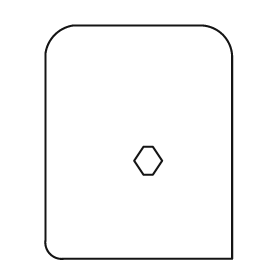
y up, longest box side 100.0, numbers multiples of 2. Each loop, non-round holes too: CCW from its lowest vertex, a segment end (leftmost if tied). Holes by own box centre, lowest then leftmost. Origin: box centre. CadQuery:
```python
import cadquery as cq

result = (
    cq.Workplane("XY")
    .moveTo(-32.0, -50.0)
    .lineTo(40.0, -50.0)
    .lineTo(40.0, 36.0)
    .threePointArc((36.0, 46.0), (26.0, 50.0))
    .lineTo(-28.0, 50.0)
    .threePointArc((-36.0, 46.0), (-40.0, 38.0))
    .lineTo(-40.0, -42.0)
    .threePointArc((-38.0, -48.0), (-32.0, -50.0))
    .close()
    .moveTo(2.0, -14.0)
    .lineTo(6.0, -14.0)
    .lineTo(10.0, -8.0)
    .lineTo(6.0, -2.0)
    .lineTo(2.0, -2.0)
    .lineTo(-2.0, -8.0)
    .close()
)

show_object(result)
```